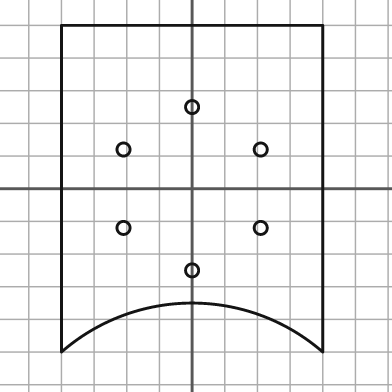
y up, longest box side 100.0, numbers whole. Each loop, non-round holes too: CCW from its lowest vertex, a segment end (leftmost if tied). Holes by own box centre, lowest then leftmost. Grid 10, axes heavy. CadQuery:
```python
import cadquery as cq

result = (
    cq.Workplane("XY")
    .moveTo(-40.0, -50.0)
    .threePointArc((0.0, -35.0), (40.0, -50.0))
    .lineTo(40.0, 50.0)
    .lineTo(-40.0, 50.0)
    .close()
    .moveTo(0.0, -25.0)
    .circle(2.0)
    .moveTo(-21.0, -12.0)
    .circle(2.0)
    .moveTo(21.0, -12.0)
    .circle(2.0)
    .moveTo(-21.0, 12.0)
    .circle(2.0)
    .moveTo(21.0, 12.0)
    .circle(2.0)
    .moveTo(0.0, 25.0)
    .circle(2.0)
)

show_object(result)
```